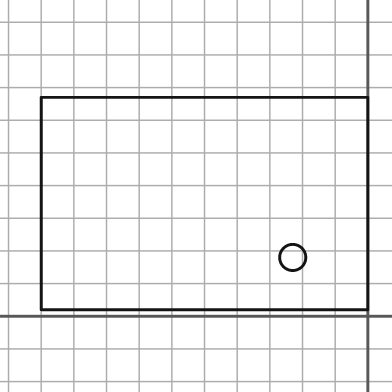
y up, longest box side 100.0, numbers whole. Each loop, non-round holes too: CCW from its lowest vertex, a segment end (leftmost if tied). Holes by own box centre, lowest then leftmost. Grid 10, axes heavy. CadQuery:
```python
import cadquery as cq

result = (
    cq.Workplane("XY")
    .moveTo(-100.0, 2.0)
    .lineTo(0.0, 2.0)
    .lineTo(0.0, 67.0)
    .lineTo(-100.0, 67.0)
    .close()
    .moveTo(-23.0, 18.0)
    .circle(4.0)
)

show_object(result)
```